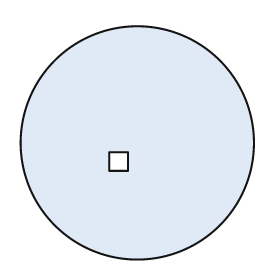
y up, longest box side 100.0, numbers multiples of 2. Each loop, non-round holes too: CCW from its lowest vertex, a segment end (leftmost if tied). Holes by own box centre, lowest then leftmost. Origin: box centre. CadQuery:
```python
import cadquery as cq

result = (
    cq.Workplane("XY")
    .moveTo(0.0, 0.0)
    .circle(50.0)
    .moveTo(-12.0, -12.0)
    .lineTo(-4.0, -12.0)
    .lineTo(-4.0, -4.0)
    .lineTo(-12.0, -4.0)
    .close()
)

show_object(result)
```